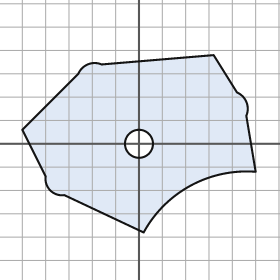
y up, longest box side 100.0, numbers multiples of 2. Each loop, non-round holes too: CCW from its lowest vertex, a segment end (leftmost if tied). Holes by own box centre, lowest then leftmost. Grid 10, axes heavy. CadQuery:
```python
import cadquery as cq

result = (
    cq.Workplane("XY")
    .moveTo(2.0, -38.0)
    .threePointArc((22.0, -18.0), (50.0, -12.0))
    .lineTo(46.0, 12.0)
    .threePointArc((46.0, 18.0), (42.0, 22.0))
    .lineTo(32.0, 38.0)
    .lineTo(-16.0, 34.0)
    .threePointArc((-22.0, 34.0), (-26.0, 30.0))
    .lineTo(-50.0, 6.0)
    .lineTo(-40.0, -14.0)
    .threePointArc((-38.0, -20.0), (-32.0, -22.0))
    .close()
    .moveTo(0.0, 0.0)
    .circle(6.0)
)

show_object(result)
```